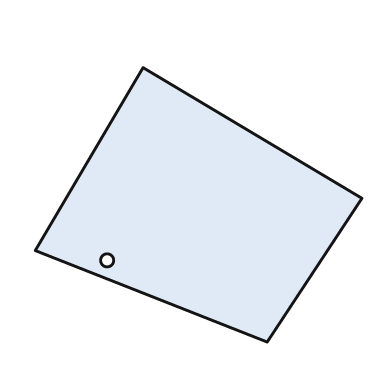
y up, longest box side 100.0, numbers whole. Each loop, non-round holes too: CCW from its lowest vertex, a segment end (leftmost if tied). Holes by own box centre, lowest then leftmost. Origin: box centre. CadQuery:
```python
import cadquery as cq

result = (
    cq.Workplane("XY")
    .moveTo(21.0, -42.0)
    .lineTo(50.0, 2.0)
    .lineTo(-17.0, 42.0)
    .lineTo(-50.0, -14.0)
    .close()
    .moveTo(-28.0, -17.0)
    .circle(2.0)
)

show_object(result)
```